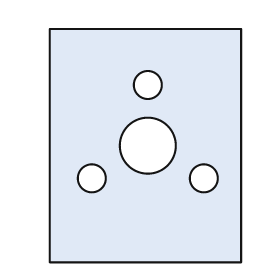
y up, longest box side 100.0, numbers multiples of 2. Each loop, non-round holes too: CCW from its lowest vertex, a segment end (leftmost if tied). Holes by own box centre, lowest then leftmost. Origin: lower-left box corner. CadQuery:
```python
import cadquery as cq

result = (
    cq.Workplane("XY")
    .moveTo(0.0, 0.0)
    .lineTo(82.0, 0.0)
    .lineTo(82.0, 100.0)
    .lineTo(0.0, 100.0)
    .close()
    .moveTo(18.0, 36.0)
    .circle(6.0)
    .moveTo(66.0, 36.0)
    .circle(6.0)
    .moveTo(42.0, 50.0)
    .circle(12.0)
    .moveTo(42.0, 76.0)
    .circle(6.0)
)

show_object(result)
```